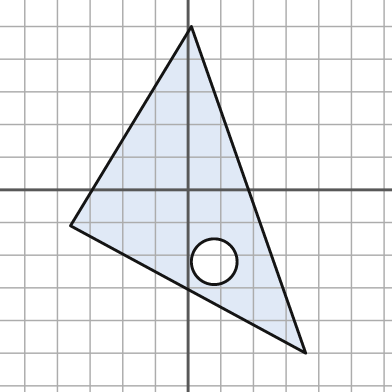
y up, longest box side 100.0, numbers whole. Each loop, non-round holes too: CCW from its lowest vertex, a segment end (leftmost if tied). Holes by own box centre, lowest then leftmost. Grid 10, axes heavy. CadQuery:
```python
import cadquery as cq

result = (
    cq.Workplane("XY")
    .moveTo(36.0, -50.0)
    .lineTo(1.0, 50.0)
    .lineTo(-36.0, -11.0)
    .close()
    .moveTo(8.0, -22.0)
    .circle(7.0)
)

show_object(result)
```